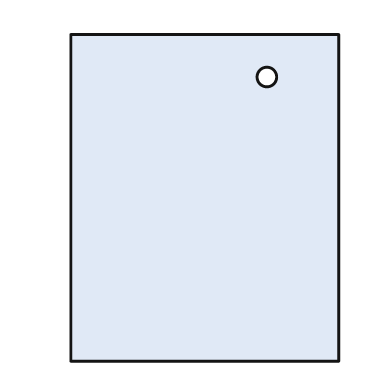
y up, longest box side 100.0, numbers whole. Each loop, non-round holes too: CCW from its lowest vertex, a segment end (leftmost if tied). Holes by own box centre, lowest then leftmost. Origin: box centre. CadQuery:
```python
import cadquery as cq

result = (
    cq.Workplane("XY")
    .moveTo(-41.0, -50.0)
    .lineTo(41.0, -50.0)
    .lineTo(41.0, 50.0)
    .lineTo(-41.0, 50.0)
    .close()
    .moveTo(19.0, 37.0)
    .circle(3.0)
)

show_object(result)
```